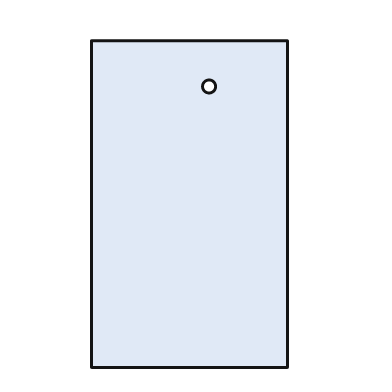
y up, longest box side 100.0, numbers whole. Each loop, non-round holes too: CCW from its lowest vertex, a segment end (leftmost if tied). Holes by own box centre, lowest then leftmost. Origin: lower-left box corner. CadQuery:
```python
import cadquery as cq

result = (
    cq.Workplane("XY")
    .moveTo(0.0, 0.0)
    .lineTo(60.0, 0.0)
    .lineTo(60.0, 100.0)
    .lineTo(0.0, 100.0)
    .close()
    .moveTo(36.0, 86.0)
    .circle(2.0)
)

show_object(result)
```